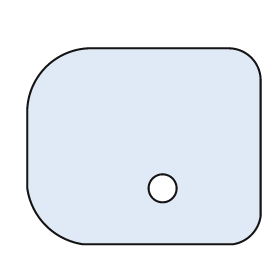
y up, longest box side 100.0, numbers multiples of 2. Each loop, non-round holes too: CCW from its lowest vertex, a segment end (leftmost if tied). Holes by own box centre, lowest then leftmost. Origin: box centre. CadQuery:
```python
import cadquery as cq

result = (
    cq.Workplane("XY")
    .moveTo(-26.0, -42.0)
    .lineTo(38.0, -42.0)
    .threePointArc((46.0, -38.0), (50.0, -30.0))
    .lineTo(50.0, 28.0)
    .threePointArc((46.0, 38.0), (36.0, 42.0))
    .lineTo(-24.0, 42.0)
    .threePointArc((-42.0, 34.0), (-50.0, 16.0))
    .lineTo(-50.0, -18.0)
    .threePointArc((-42.0, -34.0), (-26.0, -42.0))
    .close()
    .moveTo(8.0, -18.0)
    .circle(6.0)
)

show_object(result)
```